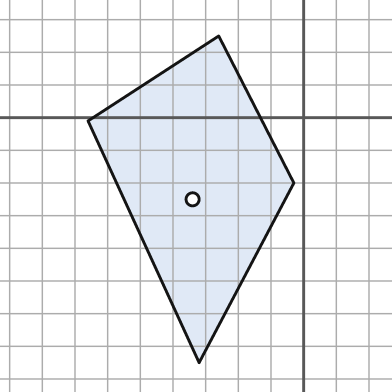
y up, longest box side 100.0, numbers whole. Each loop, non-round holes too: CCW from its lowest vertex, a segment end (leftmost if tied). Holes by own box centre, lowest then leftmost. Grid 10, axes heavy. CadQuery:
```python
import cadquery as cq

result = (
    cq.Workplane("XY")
    .moveTo(-32.0, -75.0)
    .lineTo(-3.0, -20.0)
    .lineTo(-26.0, 25.0)
    .lineTo(-66.0, -1.0)
    .close()
    .moveTo(-34.0, -25.0)
    .circle(2.0)
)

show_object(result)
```